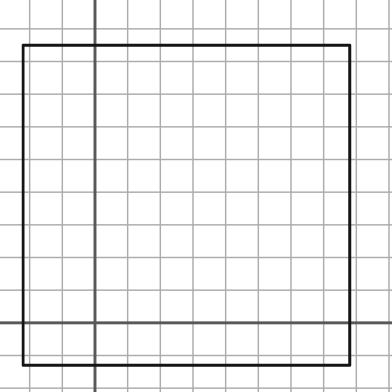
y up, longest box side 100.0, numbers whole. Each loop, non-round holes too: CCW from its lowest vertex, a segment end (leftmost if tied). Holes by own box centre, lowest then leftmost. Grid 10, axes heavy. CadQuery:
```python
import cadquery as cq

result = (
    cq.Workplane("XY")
    .moveTo(-22.0, -13.0)
    .lineTo(78.0, -13.0)
    .lineTo(78.0, 85.0)
    .lineTo(-22.0, 85.0)
    .close()
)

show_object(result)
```